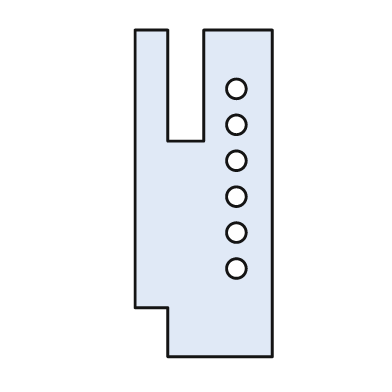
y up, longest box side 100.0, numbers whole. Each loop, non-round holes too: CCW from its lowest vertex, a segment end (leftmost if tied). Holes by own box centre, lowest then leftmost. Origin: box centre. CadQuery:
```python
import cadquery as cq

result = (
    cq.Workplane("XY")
    .moveTo(-11.0, -50.0)
    .lineTo(21.0, -50.0)
    .lineTo(21.0, 50.0)
    .lineTo(0.0, 50.0)
    .lineTo(0.0, 16.0)
    .lineTo(-11.0, 16.0)
    .lineTo(-11.0, 50.0)
    .lineTo(-21.0, 50.0)
    .lineTo(-21.0, -35.0)
    .lineTo(-11.0, -35.0)
    .close()
    .moveTo(10.0, -23.0)
    .circle(3.0)
    .moveTo(10.0, -12.0)
    .circle(3.0)
    .moveTo(10.0, -1.0)
    .circle(3.0)
    .moveTo(10.0, 10.0)
    .circle(3.0)
    .moveTo(10.0, 21.0)
    .circle(3.0)
    .moveTo(10.0, 32.0)
    .circle(3.0)
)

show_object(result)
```